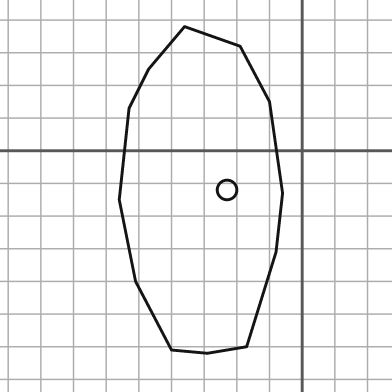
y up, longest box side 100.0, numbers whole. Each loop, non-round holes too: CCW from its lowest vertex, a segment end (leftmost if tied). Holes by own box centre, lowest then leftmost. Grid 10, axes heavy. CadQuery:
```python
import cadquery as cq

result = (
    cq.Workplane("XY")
    .moveTo(-29.0, -62.0)
    .lineTo(-17.0, -60.0)
    .lineTo(-8.0, -31.0)
    .lineTo(-6.0, -13.0)
    .lineTo(-10.0, 15.0)
    .lineTo(-19.0, 32.0)
    .lineTo(-36.0, 38.0)
    .lineTo(-47.0, 25.0)
    .lineTo(-53.0, 13.0)
    .lineTo(-56.0, -15.0)
    .lineTo(-51.0, -40.0)
    .lineTo(-40.0, -61.0)
    .close()
    .moveTo(-23.0, -12.0)
    .circle(3.0)
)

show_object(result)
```